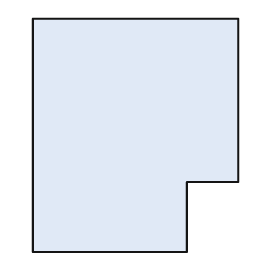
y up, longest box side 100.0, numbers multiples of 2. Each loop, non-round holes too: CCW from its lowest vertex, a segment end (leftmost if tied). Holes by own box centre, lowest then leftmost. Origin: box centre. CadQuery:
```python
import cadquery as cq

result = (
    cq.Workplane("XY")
    .moveTo(-44.0, -50.0)
    .lineTo(22.0, -50.0)
    .lineTo(22.0, -20.0)
    .lineTo(44.0, -20.0)
    .lineTo(44.0, 50.0)
    .lineTo(-44.0, 50.0)
    .close()
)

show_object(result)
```